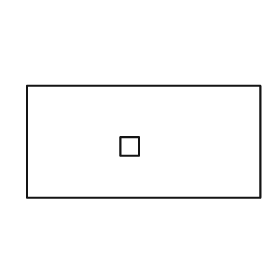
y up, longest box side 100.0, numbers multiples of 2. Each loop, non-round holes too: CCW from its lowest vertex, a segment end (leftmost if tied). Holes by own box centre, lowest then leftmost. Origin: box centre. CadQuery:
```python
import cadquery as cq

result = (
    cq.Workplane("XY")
    .moveTo(-50.0, -24.0)
    .lineTo(50.0, -24.0)
    .lineTo(50.0, 24.0)
    .lineTo(-50.0, 24.0)
    .close()
    .moveTo(-10.0, -6.0)
    .lineTo(-2.0, -6.0)
    .lineTo(-2.0, 2.0)
    .lineTo(-10.0, 2.0)
    .close()
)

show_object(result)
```